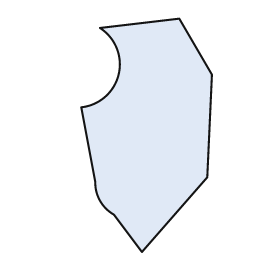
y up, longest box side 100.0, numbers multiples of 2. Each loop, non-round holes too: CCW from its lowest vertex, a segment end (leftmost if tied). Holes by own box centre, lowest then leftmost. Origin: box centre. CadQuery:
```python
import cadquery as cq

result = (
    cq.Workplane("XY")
    .moveTo(-2.0, -50.0)
    .lineTo(26.0, -18.0)
    .lineTo(28.0, 26.0)
    .lineTo(14.0, 50.0)
    .lineTo(-20.0, 46.0)
    .threePointArc((-12.0, 26.0), (-28.0, 12.0))
    .lineTo(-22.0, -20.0)
    .threePointArc((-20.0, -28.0), (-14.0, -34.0))
    .close()
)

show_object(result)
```